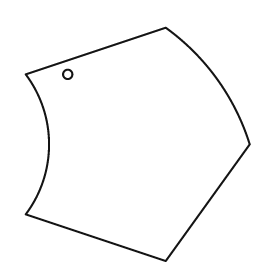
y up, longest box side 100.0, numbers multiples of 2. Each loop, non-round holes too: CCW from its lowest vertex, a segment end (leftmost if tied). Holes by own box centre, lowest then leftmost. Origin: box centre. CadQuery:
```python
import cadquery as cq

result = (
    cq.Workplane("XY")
    .moveTo(12.0, -50.0)
    .lineTo(48.0, 0.0)
    .threePointArc((34.0, 28.0), (12.0, 50.0))
    .lineTo(-48.0, 30.0)
    .threePointArc((-38.0, 0.0), (-48.0, -30.0))
    .close()
    .moveTo(-30.0, 30.0)
    .circle(2.0)
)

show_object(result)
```